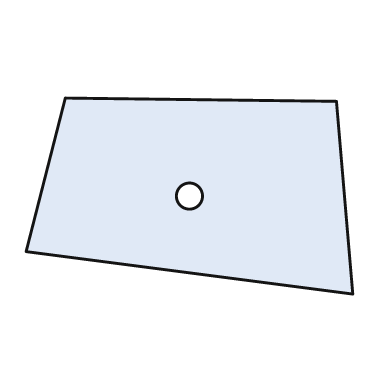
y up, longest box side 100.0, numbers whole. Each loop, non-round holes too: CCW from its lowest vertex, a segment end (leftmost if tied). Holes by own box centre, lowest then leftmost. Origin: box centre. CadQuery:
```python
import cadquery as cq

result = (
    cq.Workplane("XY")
    .moveTo(50.0, -30.0)
    .lineTo(45.0, 29.0)
    .lineTo(-38.0, 30.0)
    .lineTo(-50.0, -17.0)
    .close()
    .moveTo(0.0, 0.0)
    .circle(4.0)
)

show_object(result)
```